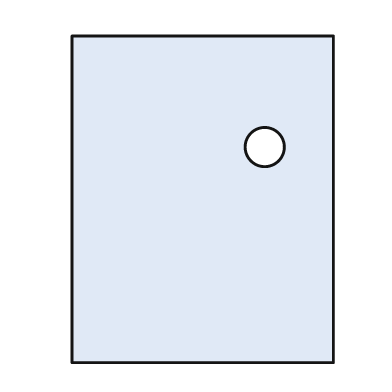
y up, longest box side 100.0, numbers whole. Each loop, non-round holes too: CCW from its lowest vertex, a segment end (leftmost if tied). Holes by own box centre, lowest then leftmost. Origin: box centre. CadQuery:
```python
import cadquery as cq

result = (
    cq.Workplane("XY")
    .moveTo(-40.0, -50.0)
    .lineTo(40.0, -50.0)
    .lineTo(40.0, 50.0)
    .lineTo(-40.0, 50.0)
    .close()
    .moveTo(19.0, 16.0)
    .circle(6.0)
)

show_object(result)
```